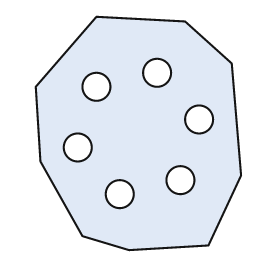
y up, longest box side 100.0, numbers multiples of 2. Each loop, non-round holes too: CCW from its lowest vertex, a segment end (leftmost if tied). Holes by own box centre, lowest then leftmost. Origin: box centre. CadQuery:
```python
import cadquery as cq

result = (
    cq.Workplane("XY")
    .moveTo(-4.0, -50.0)
    .lineTo(30.0, -48.0)
    .lineTo(44.0, -18.0)
    .lineTo(40.0, 30.0)
    .lineTo(20.0, 48.0)
    .lineTo(-18.0, 50.0)
    .lineTo(-44.0, 20.0)
    .lineTo(-42.0, -12.0)
    .lineTo(-24.0, -44.0)
    .close()
    .moveTo(-8.0, -26.0)
    .circle(6.0)
    .moveTo(18.0, -20.0)
    .circle(6.0)
    .moveTo(-26.0, -6.0)
    .circle(6.0)
    .moveTo(26.0, 6.0)
    .circle(6.0)
    .moveTo(-18.0, 20.0)
    .circle(6.0)
    .moveTo(8.0, 26.0)
    .circle(6.0)
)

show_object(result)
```